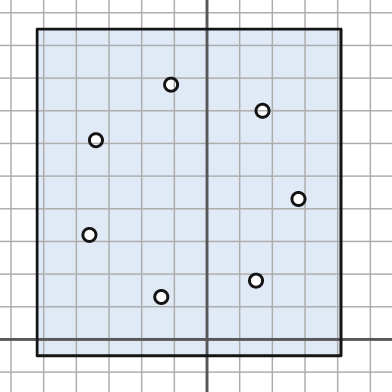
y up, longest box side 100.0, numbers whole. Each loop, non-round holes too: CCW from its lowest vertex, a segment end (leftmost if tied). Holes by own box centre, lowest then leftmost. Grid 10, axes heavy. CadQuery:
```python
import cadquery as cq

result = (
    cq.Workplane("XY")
    .moveTo(-52.0, -5.0)
    .lineTo(41.0, -5.0)
    .lineTo(41.0, 95.0)
    .lineTo(-52.0, 95.0)
    .close()
    .moveTo(-14.0, 13.0)
    .circle(2.0)
    .moveTo(15.0, 18.0)
    .circle(2.0)
    .moveTo(-36.0, 32.0)
    .circle(2.0)
    .moveTo(28.0, 43.0)
    .circle(2.0)
    .moveTo(-34.0, 61.0)
    .circle(2.0)
    .moveTo(17.0, 70.0)
    .circle(2.0)
    .moveTo(-11.0, 78.0)
    .circle(2.0)
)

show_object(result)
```